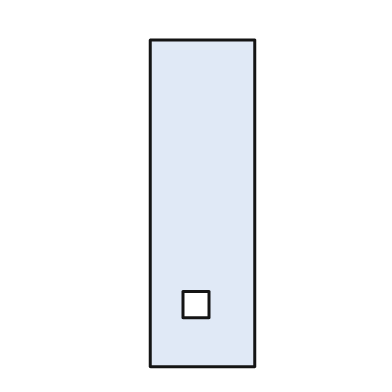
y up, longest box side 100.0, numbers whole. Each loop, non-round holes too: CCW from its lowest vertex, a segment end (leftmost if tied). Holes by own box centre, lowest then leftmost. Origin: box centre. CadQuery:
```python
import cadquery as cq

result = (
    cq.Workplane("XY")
    .moveTo(-16.0, -50.0)
    .lineTo(16.0, -50.0)
    .lineTo(16.0, 50.0)
    .lineTo(-16.0, 50.0)
    .close()
    .moveTo(-6.0, -35.0)
    .lineTo(2.0, -35.0)
    .lineTo(2.0, -27.0)
    .lineTo(-6.0, -27.0)
    .close()
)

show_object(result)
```